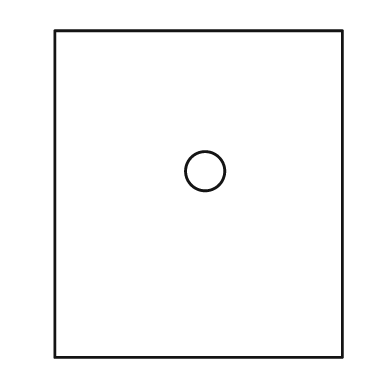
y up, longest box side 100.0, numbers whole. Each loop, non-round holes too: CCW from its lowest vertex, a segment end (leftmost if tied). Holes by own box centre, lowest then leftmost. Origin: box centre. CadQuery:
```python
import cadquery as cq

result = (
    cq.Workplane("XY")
    .moveTo(-44.0, -50.0)
    .lineTo(44.0, -50.0)
    .lineTo(44.0, 50.0)
    .lineTo(-44.0, 50.0)
    .close()
    .moveTo(2.0, 7.0)
    .circle(6.0)
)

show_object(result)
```